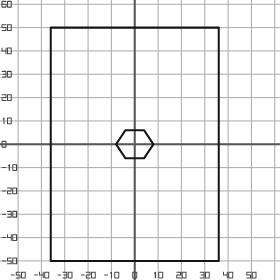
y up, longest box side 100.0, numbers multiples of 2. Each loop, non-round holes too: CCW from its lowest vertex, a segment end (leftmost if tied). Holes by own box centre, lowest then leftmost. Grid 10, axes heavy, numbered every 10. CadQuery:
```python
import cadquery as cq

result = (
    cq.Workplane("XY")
    .moveTo(-36.0, -50.0)
    .lineTo(36.0, -50.0)
    .lineTo(36.0, 50.0)
    .lineTo(-36.0, 50.0)
    .close()
    .moveTo(-4.0, -6.0)
    .lineTo(4.0, -6.0)
    .lineTo(8.0, 0.0)
    .lineTo(4.0, 6.0)
    .lineTo(-4.0, 6.0)
    .lineTo(-8.0, 0.0)
    .close()
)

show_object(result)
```